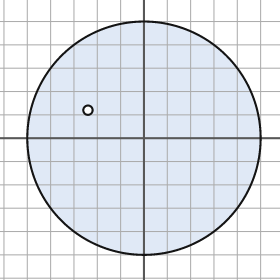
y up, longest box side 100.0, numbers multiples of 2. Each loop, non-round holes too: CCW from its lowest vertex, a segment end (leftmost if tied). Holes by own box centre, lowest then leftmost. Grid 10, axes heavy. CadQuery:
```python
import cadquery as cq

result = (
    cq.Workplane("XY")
    .moveTo(0.0, 0.0)
    .circle(50.0)
    .moveTo(-24.0, 12.0)
    .circle(2.0)
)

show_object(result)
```